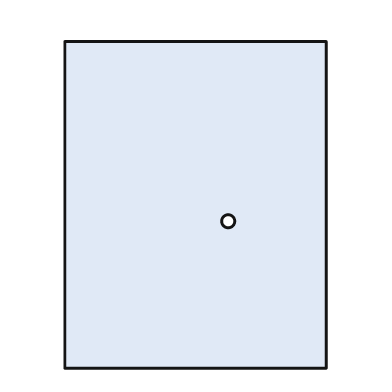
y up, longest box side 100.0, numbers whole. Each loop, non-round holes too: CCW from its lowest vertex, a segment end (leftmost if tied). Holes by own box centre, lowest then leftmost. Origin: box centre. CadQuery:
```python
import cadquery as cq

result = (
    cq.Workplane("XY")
    .moveTo(-40.0, -50.0)
    .lineTo(40.0, -50.0)
    .lineTo(40.0, 50.0)
    .lineTo(-40.0, 50.0)
    .close()
    .moveTo(10.0, -5.0)
    .circle(2.0)
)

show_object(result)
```